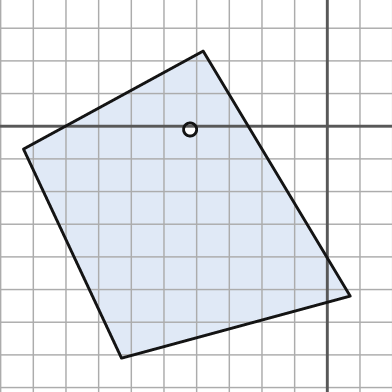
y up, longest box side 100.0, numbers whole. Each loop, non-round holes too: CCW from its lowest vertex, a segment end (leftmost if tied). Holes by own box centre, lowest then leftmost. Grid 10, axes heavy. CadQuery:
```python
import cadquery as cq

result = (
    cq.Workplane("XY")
    .moveTo(-63.0, -71.0)
    .lineTo(7.0, -52.0)
    .lineTo(-38.0, 23.0)
    .lineTo(-93.0, -7.0)
    .close()
    .moveTo(-42.0, -1.0)
    .circle(2.0)
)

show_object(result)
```